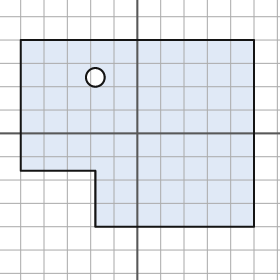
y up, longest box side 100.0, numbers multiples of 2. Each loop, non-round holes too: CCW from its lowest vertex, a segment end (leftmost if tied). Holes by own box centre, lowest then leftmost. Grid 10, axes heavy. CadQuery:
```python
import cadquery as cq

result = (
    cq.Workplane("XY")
    .moveTo(-18.0, -40.0)
    .lineTo(50.0, -40.0)
    .lineTo(50.0, 40.0)
    .lineTo(-50.0, 40.0)
    .lineTo(-50.0, -16.0)
    .lineTo(-18.0, -16.0)
    .close()
    .moveTo(-18.0, 24.0)
    .circle(4.0)
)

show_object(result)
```